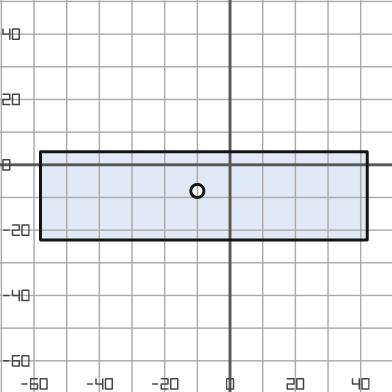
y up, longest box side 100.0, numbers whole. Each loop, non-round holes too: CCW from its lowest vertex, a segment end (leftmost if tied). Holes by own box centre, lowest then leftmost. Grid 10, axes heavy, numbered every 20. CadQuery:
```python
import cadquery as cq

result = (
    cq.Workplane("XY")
    .moveTo(-58.0, -23.0)
    .lineTo(42.0, -23.0)
    .lineTo(42.0, 4.0)
    .lineTo(-58.0, 4.0)
    .close()
    .moveTo(-10.0, -8.0)
    .circle(2.0)
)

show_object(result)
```